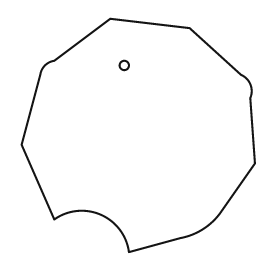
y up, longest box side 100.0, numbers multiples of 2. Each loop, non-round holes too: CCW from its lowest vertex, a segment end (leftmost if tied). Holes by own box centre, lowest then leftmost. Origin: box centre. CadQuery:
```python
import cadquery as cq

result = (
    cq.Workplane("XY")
    .moveTo(-4.0, -50.0)
    .lineTo(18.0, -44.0)
    .threePointArc((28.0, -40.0), (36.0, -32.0))
    .lineTo(50.0, -12.0)
    .lineTo(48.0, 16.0)
    .threePointArc((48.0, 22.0), (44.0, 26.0))
    .lineTo(22.0, 46.0)
    .lineTo(-12.0, 50.0)
    .lineTo(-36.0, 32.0)
    .threePointArc((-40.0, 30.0), (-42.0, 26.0))
    .lineTo(-50.0, -4.0)
    .lineTo(-36.0, -36.0)
    .threePointArc((-16.0, -34.0), (-4.0, -50.0))
    .close()
    .moveTo(-6.0, 30.0)
    .circle(2.0)
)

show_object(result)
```